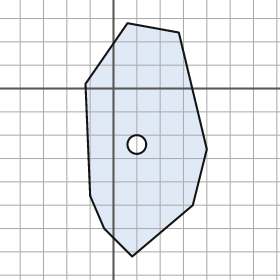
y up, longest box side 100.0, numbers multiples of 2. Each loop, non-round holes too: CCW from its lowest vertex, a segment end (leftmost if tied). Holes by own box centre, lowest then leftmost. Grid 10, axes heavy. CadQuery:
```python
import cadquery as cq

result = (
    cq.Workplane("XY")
    .moveTo(8.0, -72.0)
    .lineTo(34.0, -50.0)
    .lineTo(40.0, -26.0)
    .lineTo(28.0, 24.0)
    .lineTo(6.0, 28.0)
    .lineTo(-12.0, 2.0)
    .lineTo(-10.0, -46.0)
    .lineTo(-4.0, -60.0)
    .close()
    .moveTo(10.0, -24.0)
    .circle(4.0)
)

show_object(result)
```